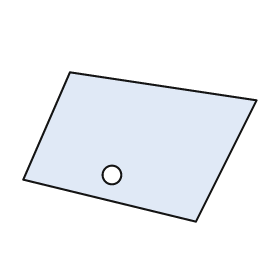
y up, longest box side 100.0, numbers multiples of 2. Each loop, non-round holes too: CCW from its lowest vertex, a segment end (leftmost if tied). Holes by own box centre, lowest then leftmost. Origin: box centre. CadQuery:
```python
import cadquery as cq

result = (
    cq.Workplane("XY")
    .moveTo(24.0, -32.0)
    .lineTo(50.0, 20.0)
    .lineTo(-30.0, 32.0)
    .lineTo(-50.0, -14.0)
    .close()
    .moveTo(-12.0, -12.0)
    .circle(4.0)
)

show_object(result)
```